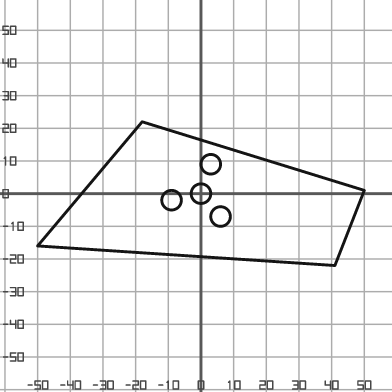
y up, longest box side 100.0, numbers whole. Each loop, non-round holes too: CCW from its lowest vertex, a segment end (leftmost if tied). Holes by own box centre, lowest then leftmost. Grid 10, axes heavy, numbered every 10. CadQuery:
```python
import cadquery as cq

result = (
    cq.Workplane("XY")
    .moveTo(41.0, -22.0)
    .lineTo(50.0, 1.0)
    .lineTo(-18.0, 22.0)
    .lineTo(-50.0, -16.0)
    .close()
    .moveTo(6.0, -7.0)
    .circle(3.0)
    .moveTo(-9.0, -2.0)
    .circle(3.0)
    .moveTo(0.0, 0.0)
    .circle(3.0)
    .moveTo(3.0, 9.0)
    .circle(3.0)
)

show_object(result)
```